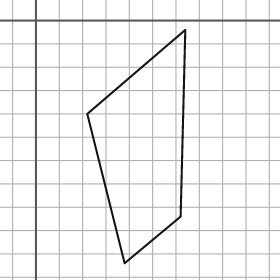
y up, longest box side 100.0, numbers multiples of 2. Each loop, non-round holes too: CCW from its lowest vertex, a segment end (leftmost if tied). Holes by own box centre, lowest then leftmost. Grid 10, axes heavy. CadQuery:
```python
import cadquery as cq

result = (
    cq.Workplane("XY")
    .moveTo(38.0, -104.0)
    .lineTo(62.0, -84.0)
    .lineTo(64.0, -4.0)
    .lineTo(22.0, -40.0)
    .close()
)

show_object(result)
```